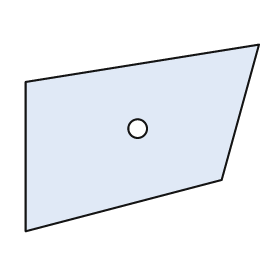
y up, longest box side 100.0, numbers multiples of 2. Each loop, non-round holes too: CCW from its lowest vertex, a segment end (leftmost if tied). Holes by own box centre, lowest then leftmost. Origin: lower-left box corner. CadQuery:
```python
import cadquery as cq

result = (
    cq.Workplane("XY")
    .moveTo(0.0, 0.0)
    .lineTo(84.0, 22.0)
    .lineTo(100.0, 80.0)
    .lineTo(0.0, 64.0)
    .close()
    .moveTo(48.0, 44.0)
    .circle(4.0)
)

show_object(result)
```